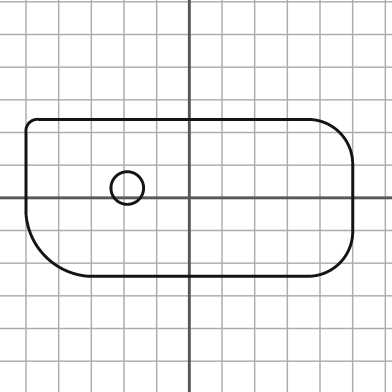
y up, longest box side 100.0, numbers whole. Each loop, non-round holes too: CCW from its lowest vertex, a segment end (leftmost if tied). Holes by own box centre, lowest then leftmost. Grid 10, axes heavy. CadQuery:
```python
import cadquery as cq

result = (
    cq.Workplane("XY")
    .moveTo(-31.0, -24.0)
    .lineTo(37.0, -24.0)
    .threePointArc((46.0, -20.0), (50.0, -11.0))
    .lineTo(50.0, 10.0)
    .threePointArc((46.0, 20.0), (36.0, 24.0))
    .lineTo(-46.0, 24.0)
    .threePointArc((-49.0, 23.0), (-50.0, 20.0))
    .lineTo(-50.0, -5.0)
    .threePointArc((-44.0, -18.0), (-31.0, -24.0))
    .close()
    .moveTo(-19.0, 3.0)
    .circle(5.0)
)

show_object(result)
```